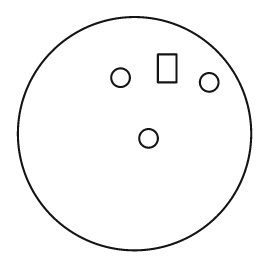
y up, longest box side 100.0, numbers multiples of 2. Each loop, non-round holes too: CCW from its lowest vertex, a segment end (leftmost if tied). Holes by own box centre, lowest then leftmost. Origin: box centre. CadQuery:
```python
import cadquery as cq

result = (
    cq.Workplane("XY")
    .moveTo(0.0, 0.0)
    .circle(50.0)
    .moveTo(6.0, -2.0)
    .circle(4.0)
    .moveTo(32.0, 22.0)
    .circle(4.0)
    .moveTo(-6.0, 24.0)
    .circle(4.0)
    .moveTo(10.0, 22.0)
    .lineTo(18.0, 22.0)
    .lineTo(18.0, 34.0)
    .lineTo(10.0, 34.0)
    .close()
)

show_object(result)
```